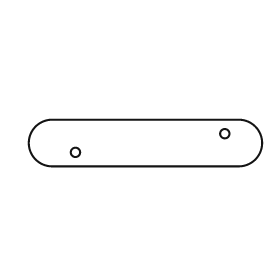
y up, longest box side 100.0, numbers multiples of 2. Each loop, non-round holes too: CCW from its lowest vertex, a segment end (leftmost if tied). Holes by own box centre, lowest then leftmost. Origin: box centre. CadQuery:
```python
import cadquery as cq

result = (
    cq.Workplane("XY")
    .moveTo(-40.0, -10.0)
    .lineTo(40.0, -10.0)
    .threePointArc((50.0, 0.0), (40.0, 10.0))
    .lineTo(-40.0, 10.0)
    .threePointArc((-50.0, 0.0), (-40.0, -10.0))
    .close()
    .moveTo(-30.0, -4.0)
    .circle(2.0)
    .moveTo(34.0, 4.0)
    .circle(2.0)
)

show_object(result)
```